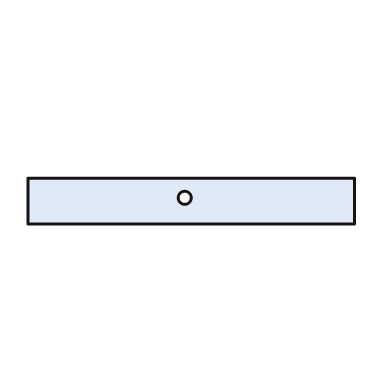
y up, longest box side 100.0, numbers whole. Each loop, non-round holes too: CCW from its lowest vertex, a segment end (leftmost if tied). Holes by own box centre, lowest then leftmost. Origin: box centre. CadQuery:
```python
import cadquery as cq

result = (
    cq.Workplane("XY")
    .moveTo(-50.0, -7.0)
    .lineTo(50.0, -7.0)
    .lineTo(50.0, 7.0)
    .lineTo(-50.0, 7.0)
    .close()
    .moveTo(-2.0, 1.0)
    .circle(2.0)
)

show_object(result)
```